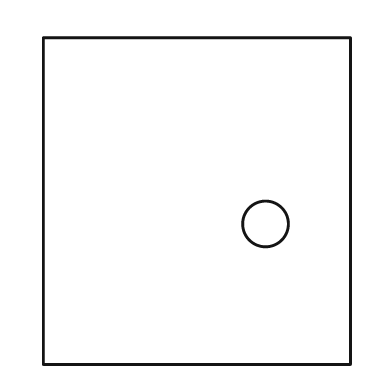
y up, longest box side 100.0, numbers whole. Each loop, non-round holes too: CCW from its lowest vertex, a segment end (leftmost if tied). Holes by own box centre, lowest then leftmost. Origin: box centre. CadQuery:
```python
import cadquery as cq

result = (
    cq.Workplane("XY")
    .moveTo(-47.0, -50.0)
    .lineTo(47.0, -50.0)
    .lineTo(47.0, 50.0)
    .lineTo(-47.0, 50.0)
    .close()
    .moveTo(21.0, -7.0)
    .circle(7.0)
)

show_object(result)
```